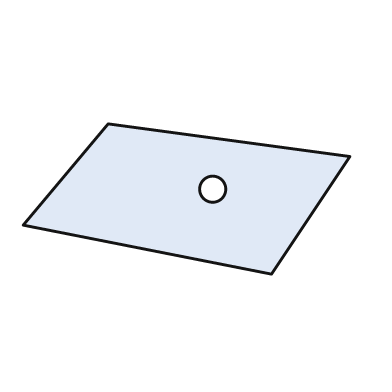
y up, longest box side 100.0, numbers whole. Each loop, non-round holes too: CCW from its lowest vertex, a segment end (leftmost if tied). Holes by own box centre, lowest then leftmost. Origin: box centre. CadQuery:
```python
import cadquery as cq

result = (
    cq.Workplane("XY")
    .moveTo(26.0, -23.0)
    .lineTo(50.0, 13.0)
    .lineTo(-24.0, 23.0)
    .lineTo(-50.0, -8.0)
    .close()
    .moveTo(8.0, 3.0)
    .circle(4.0)
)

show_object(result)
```